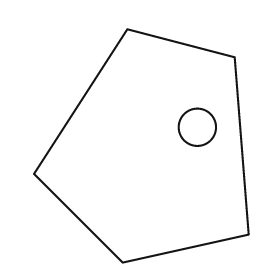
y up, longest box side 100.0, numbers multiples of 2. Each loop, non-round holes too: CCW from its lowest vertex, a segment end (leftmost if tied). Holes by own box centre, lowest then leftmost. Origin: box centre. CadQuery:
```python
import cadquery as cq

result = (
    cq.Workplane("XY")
    .moveTo(-8.0, -50.0)
    .lineTo(46.0, -38.0)
    .lineTo(40.0, 38.0)
    .lineTo(-6.0, 50.0)
    .lineTo(-46.0, -12.0)
    .close()
    .moveTo(24.0, 8.0)
    .circle(8.0)
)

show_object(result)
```